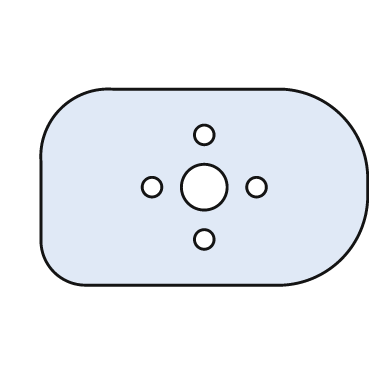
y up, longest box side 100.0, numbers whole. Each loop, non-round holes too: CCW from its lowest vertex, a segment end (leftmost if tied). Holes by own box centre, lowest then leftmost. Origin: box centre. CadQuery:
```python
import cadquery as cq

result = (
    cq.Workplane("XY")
    .moveTo(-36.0, -30.0)
    .lineTo(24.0, -30.0)
    .threePointArc((42.0, -22.0), (50.0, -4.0))
    .lineTo(50.0, 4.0)
    .threePointArc((42.0, 22.0), (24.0, 30.0))
    .lineTo(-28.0, 30.0)
    .threePointArc((-44.0, 24.0), (-50.0, 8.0))
    .lineTo(-50.0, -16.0)
    .threePointArc((-46.0, -26.0), (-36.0, -30.0))
    .close()
    .moveTo(0.0, -16.0)
    .circle(3.0)
    .moveTo(-16.0, 0.0)
    .circle(3.0)
    .moveTo(0.0, 0.0)
    .circle(7.0)
    .moveTo(16.0, 0.0)
    .circle(3.0)
    .moveTo(0.0, 16.0)
    .circle(3.0)
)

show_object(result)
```